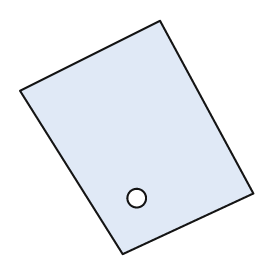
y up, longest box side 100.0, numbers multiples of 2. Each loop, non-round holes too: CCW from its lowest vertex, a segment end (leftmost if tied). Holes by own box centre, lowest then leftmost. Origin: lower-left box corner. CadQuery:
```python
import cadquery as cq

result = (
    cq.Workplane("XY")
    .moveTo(44.0, 0.0)
    .lineTo(100.0, 26.0)
    .lineTo(60.0, 100.0)
    .lineTo(0.0, 70.0)
    .close()
    .moveTo(50.0, 24.0)
    .circle(4.0)
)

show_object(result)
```